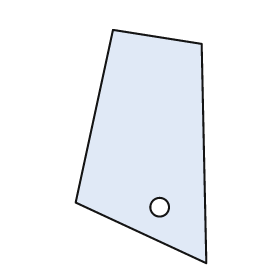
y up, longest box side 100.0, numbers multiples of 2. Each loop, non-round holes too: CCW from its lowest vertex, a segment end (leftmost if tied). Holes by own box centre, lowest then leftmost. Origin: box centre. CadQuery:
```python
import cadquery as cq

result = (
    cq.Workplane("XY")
    .moveTo(28.0, -50.0)
    .lineTo(26.0, 44.0)
    .lineTo(-12.0, 50.0)
    .lineTo(-28.0, -24.0)
    .close()
    .moveTo(8.0, -26.0)
    .circle(4.0)
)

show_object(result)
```